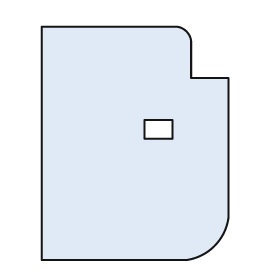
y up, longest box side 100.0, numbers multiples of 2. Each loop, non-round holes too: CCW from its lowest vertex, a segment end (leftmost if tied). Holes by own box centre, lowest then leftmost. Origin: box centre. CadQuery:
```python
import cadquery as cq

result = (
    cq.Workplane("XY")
    .moveTo(-40.0, -50.0)
    .lineTo(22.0, -50.0)
    .threePointArc((34.0, -44.0), (40.0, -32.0))
    .lineTo(40.0, 28.0)
    .lineTo(24.0, 28.0)
    .lineTo(24.0, 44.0)
    .threePointArc((22.0, 48.0), (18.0, 50.0))
    .lineTo(-40.0, 50.0)
    .close()
    .moveTo(4.0, 2.0)
    .lineTo(16.0, 2.0)
    .lineTo(16.0, 10.0)
    .lineTo(4.0, 10.0)
    .close()
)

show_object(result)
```